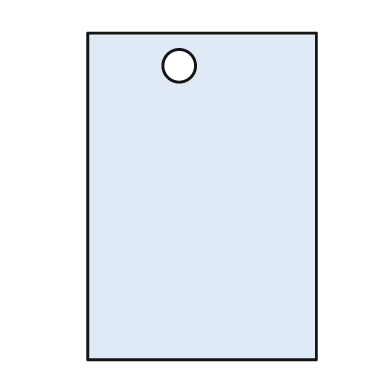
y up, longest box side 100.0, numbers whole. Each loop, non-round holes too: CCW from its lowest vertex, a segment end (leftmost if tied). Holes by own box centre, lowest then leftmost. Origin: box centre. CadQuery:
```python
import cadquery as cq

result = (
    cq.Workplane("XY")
    .moveTo(-35.0, -50.0)
    .lineTo(35.0, -50.0)
    .lineTo(35.0, 50.0)
    .lineTo(-35.0, 50.0)
    .close()
    .moveTo(-7.0, 40.0)
    .circle(5.0)
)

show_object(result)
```